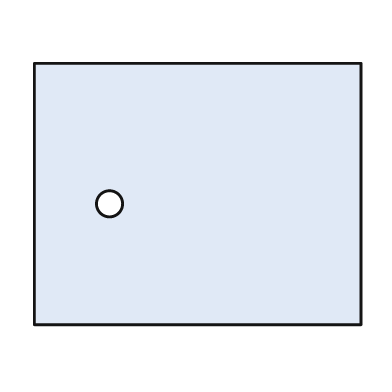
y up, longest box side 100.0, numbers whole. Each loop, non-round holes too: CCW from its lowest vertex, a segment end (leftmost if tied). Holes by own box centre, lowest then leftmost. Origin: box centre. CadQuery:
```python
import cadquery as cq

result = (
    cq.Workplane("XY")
    .moveTo(-50.0, -40.0)
    .lineTo(50.0, -40.0)
    .lineTo(50.0, 40.0)
    .lineTo(-50.0, 40.0)
    .close()
    .moveTo(-27.0, -3.0)
    .circle(4.0)
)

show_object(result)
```